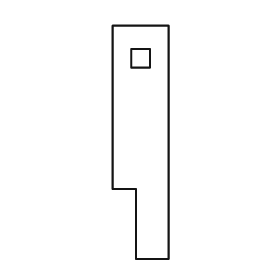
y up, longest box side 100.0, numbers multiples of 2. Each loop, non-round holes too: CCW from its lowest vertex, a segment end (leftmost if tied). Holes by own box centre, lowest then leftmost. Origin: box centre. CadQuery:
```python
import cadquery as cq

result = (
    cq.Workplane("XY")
    .moveTo(-2.0, -50.0)
    .lineTo(12.0, -50.0)
    .lineTo(12.0, 50.0)
    .lineTo(-12.0, 50.0)
    .lineTo(-12.0, -20.0)
    .lineTo(-2.0, -20.0)
    .close()
    .moveTo(-4.0, 32.0)
    .lineTo(4.0, 32.0)
    .lineTo(4.0, 40.0)
    .lineTo(-4.0, 40.0)
    .close()
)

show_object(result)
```